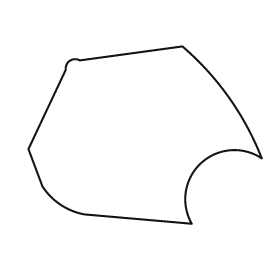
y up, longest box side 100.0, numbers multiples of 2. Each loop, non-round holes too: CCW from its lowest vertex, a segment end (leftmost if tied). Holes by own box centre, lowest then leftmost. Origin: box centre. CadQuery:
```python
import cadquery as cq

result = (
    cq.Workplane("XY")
    .moveTo(20.0, -38.0)
    .threePointArc((24.0, -12.0), (50.0, -10.0))
    .threePointArc((36.0, 16.0), (16.0, 38.0))
    .lineTo(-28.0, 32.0)
    .threePointArc((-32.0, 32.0), (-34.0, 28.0))
    .lineTo(-50.0, -6.0)
    .lineTo(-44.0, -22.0)
    .threePointArc((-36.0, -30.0), (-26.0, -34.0))
    .close()
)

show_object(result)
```